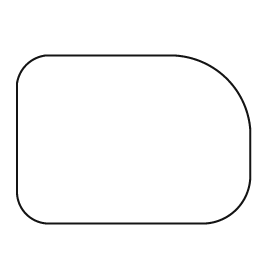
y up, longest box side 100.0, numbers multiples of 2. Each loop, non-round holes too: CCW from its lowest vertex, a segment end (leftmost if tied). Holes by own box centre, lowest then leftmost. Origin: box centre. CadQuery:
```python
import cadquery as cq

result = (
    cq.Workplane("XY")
    .moveTo(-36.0, -36.0)
    .lineTo(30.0, -36.0)
    .threePointArc((44.0, -30.0), (50.0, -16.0))
    .lineTo(50.0, 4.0)
    .threePointArc((40.0, 26.0), (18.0, 36.0))
    .lineTo(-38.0, 36.0)
    .threePointArc((-46.0, 32.0), (-50.0, 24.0))
    .lineTo(-50.0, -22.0)
    .threePointArc((-46.0, -32.0), (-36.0, -36.0))
    .close()
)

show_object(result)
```